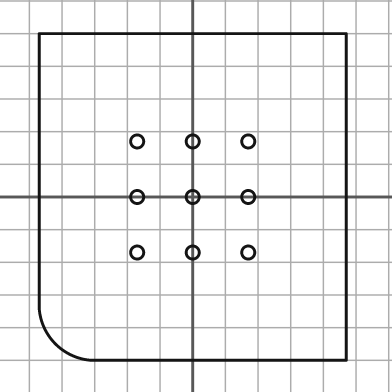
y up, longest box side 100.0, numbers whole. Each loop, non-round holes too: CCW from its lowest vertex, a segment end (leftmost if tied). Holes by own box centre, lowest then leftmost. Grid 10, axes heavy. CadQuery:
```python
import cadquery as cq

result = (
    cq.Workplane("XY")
    .moveTo(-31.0, -50.0)
    .lineTo(47.0, -50.0)
    .lineTo(47.0, 50.0)
    .lineTo(-47.0, 50.0)
    .lineTo(-47.0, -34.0)
    .threePointArc((-42.0, -45.0), (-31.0, -50.0))
    .close()
    .moveTo(-17.0, -17.0)
    .circle(2.0)
    .moveTo(0.0, -17.0)
    .circle(2.0)
    .moveTo(17.0, -17.0)
    .circle(2.0)
    .moveTo(-17.0, 0.0)
    .circle(2.0)
    .moveTo(0.0, 0.0)
    .circle(2.0)
    .moveTo(17.0, 0.0)
    .circle(2.0)
    .moveTo(-17.0, 17.0)
    .circle(2.0)
    .moveTo(0.0, 17.0)
    .circle(2.0)
    .moveTo(17.0, 17.0)
    .circle(2.0)
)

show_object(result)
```